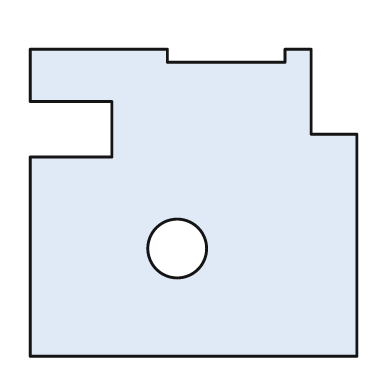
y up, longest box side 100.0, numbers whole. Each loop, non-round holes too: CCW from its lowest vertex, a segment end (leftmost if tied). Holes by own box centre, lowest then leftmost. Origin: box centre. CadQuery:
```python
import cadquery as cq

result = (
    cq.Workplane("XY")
    .moveTo(-50.0, -47.0)
    .lineTo(50.0, -47.0)
    .lineTo(50.0, 21.0)
    .lineTo(36.0, 21.0)
    .lineTo(36.0, 47.0)
    .lineTo(28.0, 47.0)
    .lineTo(28.0, 43.0)
    .lineTo(-8.0, 43.0)
    .lineTo(-8.0, 47.0)
    .lineTo(-50.0, 47.0)
    .lineTo(-50.0, 31.0)
    .lineTo(-25.0, 31.0)
    .lineTo(-25.0, 14.0)
    .lineTo(-50.0, 14.0)
    .close()
    .moveTo(-5.0, -14.0)
    .circle(9.0)
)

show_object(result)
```